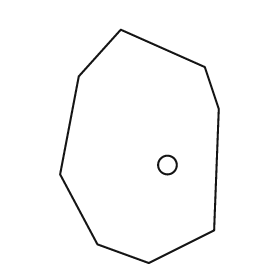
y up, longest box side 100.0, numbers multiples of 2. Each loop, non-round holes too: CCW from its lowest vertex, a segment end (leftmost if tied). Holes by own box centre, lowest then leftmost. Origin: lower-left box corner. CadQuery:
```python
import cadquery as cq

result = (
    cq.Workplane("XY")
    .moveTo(38.0, 0.0)
    .lineTo(66.0, 14.0)
    .lineTo(68.0, 66.0)
    .lineTo(62.0, 84.0)
    .lineTo(26.0, 100.0)
    .lineTo(8.0, 80.0)
    .lineTo(0.0, 38.0)
    .lineTo(16.0, 8.0)
    .close()
    .moveTo(46.0, 42.0)
    .circle(4.0)
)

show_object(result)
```